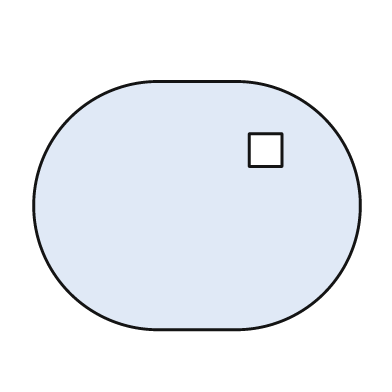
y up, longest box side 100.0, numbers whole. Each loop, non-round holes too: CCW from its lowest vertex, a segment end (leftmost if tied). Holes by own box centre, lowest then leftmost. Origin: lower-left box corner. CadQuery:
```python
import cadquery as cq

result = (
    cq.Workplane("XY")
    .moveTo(38.0, 0.0)
    .lineTo(62.0, 0.0)
    .threePointArc((100.0, 38.0), (62.0, 76.0))
    .lineTo(38.0, 76.0)
    .threePointArc((0.0, 38.0), (38.0, 0.0))
    .close()
    .moveTo(66.0, 50.0)
    .lineTo(76.0, 50.0)
    .lineTo(76.0, 60.0)
    .lineTo(66.0, 60.0)
    .close()
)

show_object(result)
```